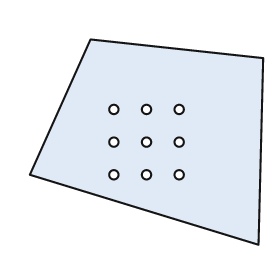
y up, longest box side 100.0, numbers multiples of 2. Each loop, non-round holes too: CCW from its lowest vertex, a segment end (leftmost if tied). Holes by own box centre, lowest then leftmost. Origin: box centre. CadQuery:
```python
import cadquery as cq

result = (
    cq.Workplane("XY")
    .moveTo(48.0, -44.0)
    .lineTo(50.0, 36.0)
    .lineTo(-24.0, 44.0)
    .lineTo(-50.0, -14.0)
    .close()
    .moveTo(-14.0, -14.0)
    .circle(2.0)
    .moveTo(0.0, -14.0)
    .circle(2.0)
    .moveTo(14.0, -14.0)
    .circle(2.0)
    .moveTo(-14.0, 0.0)
    .circle(2.0)
    .moveTo(0.0, 0.0)
    .circle(2.0)
    .moveTo(14.0, 0.0)
    .circle(2.0)
    .moveTo(-14.0, 14.0)
    .circle(2.0)
    .moveTo(0.0, 14.0)
    .circle(2.0)
    .moveTo(14.0, 14.0)
    .circle(2.0)
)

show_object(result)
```